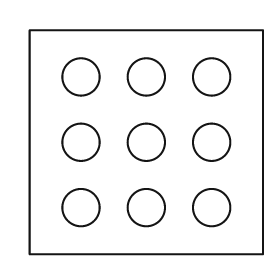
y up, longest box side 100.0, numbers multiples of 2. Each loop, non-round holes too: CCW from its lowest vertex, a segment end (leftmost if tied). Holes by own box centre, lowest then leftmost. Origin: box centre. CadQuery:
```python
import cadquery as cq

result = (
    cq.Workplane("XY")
    .moveTo(-50.0, -48.0)
    .lineTo(50.0, -48.0)
    .lineTo(50.0, 48.0)
    .lineTo(-50.0, 48.0)
    .close()
    .moveTo(-28.0, -28.0)
    .circle(8.0)
    .moveTo(0.0, -28.0)
    .circle(8.0)
    .moveTo(28.0, -28.0)
    .circle(8.0)
    .moveTo(-28.0, 0.0)
    .circle(8.0)
    .moveTo(0.0, 0.0)
    .circle(8.0)
    .moveTo(28.0, 0.0)
    .circle(8.0)
    .moveTo(-28.0, 28.0)
    .circle(8.0)
    .moveTo(0.0, 28.0)
    .circle(8.0)
    .moveTo(28.0, 28.0)
    .circle(8.0)
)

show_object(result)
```